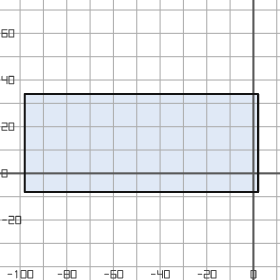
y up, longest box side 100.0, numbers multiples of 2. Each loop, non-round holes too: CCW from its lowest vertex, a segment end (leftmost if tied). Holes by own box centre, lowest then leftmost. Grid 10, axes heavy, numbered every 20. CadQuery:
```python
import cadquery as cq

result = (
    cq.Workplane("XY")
    .moveTo(-98.0, -8.0)
    .lineTo(2.0, -8.0)
    .lineTo(2.0, 34.0)
    .lineTo(-98.0, 34.0)
    .close()
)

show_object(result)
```